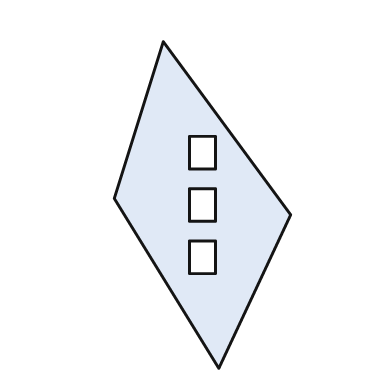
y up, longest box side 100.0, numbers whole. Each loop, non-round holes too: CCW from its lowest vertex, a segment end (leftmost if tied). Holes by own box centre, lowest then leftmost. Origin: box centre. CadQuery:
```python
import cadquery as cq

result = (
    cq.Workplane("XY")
    .moveTo(5.0, -50.0)
    .lineTo(27.0, -3.0)
    .lineTo(-12.0, 50.0)
    .lineTo(-27.0, 2.0)
    .close()
    .moveTo(-4.0, -21.0)
    .lineTo(4.0, -21.0)
    .lineTo(4.0, -11.0)
    .lineTo(-4.0, -11.0)
    .close()
    .moveTo(-4.0, -5.0)
    .lineTo(4.0, -5.0)
    .lineTo(4.0, 5.0)
    .lineTo(-4.0, 5.0)
    .close()
    .moveTo(-4.0, 11.0)
    .lineTo(4.0, 11.0)
    .lineTo(4.0, 21.0)
    .lineTo(-4.0, 21.0)
    .close()
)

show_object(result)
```